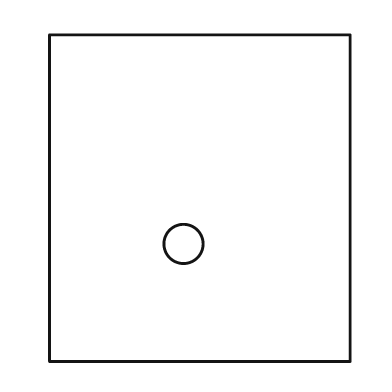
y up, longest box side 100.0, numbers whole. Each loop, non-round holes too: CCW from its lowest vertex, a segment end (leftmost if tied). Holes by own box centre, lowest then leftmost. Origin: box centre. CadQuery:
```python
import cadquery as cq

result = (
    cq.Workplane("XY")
    .moveTo(-46.0, -50.0)
    .lineTo(46.0, -50.0)
    .lineTo(46.0, 50.0)
    .lineTo(-46.0, 50.0)
    .close()
    .moveTo(-5.0, -14.0)
    .circle(6.0)
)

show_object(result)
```